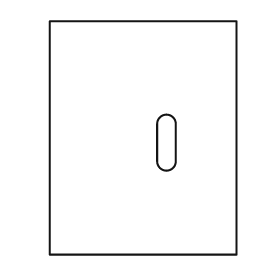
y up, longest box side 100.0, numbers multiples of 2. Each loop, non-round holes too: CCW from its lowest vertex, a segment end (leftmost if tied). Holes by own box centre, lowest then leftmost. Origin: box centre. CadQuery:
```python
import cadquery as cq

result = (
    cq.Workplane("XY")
    .moveTo(-40.0, -50.0)
    .lineTo(40.0, -50.0)
    .lineTo(40.0, 50.0)
    .lineTo(-40.0, 50.0)
    .close()
    .moveTo(6.0, -10.0)
    .threePointArc((10.0, -14.0), (14.0, -10.0))
    .lineTo(14.0, 6.0)
    .threePointArc((10.0, 10.0), (6.0, 6.0))
    .close()
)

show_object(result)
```